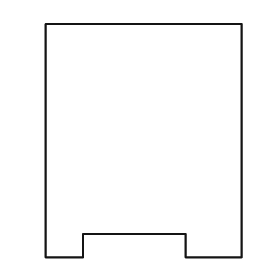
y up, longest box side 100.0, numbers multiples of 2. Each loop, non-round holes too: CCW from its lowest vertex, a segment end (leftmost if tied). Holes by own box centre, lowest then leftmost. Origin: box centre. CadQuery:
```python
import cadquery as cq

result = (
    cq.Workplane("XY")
    .moveTo(-42.0, -50.0)
    .lineTo(-26.0, -50.0)
    .lineTo(-26.0, -40.0)
    .lineTo(18.0, -40.0)
    .lineTo(18.0, -50.0)
    .lineTo(42.0, -50.0)
    .lineTo(42.0, 50.0)
    .lineTo(-42.0, 50.0)
    .close()
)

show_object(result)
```